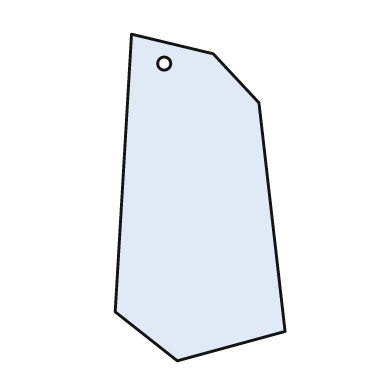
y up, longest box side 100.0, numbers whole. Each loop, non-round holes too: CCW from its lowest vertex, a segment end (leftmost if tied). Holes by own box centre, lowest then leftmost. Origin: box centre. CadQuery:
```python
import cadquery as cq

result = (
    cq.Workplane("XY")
    .moveTo(-7.0, -50.0)
    .lineTo(26.0, -41.0)
    .lineTo(18.0, 29.0)
    .lineTo(4.0, 44.0)
    .lineTo(-21.0, 50.0)
    .lineTo(-26.0, -35.0)
    .close()
    .moveTo(-11.0, 41.0)
    .circle(2.0)
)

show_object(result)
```